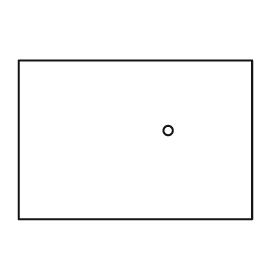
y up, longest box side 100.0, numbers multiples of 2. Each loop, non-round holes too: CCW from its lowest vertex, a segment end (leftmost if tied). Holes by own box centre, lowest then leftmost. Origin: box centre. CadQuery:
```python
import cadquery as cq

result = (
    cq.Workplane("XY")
    .moveTo(-50.0, -34.0)
    .lineTo(50.0, -34.0)
    .lineTo(50.0, 34.0)
    .lineTo(-50.0, 34.0)
    .close()
    .moveTo(14.0, 4.0)
    .circle(2.0)
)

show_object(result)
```